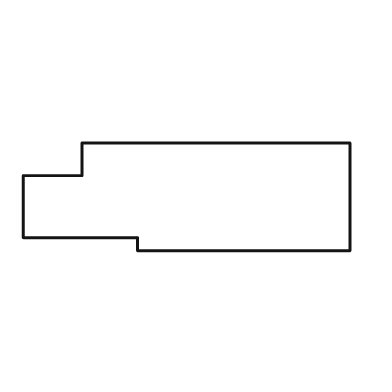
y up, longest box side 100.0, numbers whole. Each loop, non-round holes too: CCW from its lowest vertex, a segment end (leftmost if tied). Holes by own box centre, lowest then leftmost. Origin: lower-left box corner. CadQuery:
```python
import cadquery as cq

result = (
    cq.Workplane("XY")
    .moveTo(35.0, 0.0)
    .lineTo(100.0, 0.0)
    .lineTo(100.0, 33.0)
    .lineTo(18.0, 33.0)
    .lineTo(18.0, 23.0)
    .lineTo(0.0, 23.0)
    .lineTo(0.0, 4.0)
    .lineTo(35.0, 4.0)
    .close()
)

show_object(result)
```